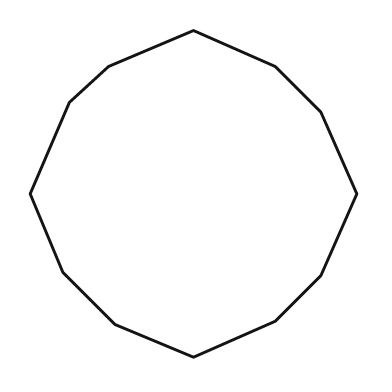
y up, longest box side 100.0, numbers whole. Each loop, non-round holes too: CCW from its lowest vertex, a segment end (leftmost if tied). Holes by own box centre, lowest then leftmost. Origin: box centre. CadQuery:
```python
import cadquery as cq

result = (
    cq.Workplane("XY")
    .moveTo(0.0, -50.0)
    .lineTo(25.0, -39.0)
    .lineTo(39.0, -25.0)
    .lineTo(50.0, 0.0)
    .lineTo(39.0, 25.0)
    .lineTo(25.0, 39.0)
    .lineTo(0.0, 50.0)
    .lineTo(-26.0, 39.0)
    .lineTo(-38.0, 28.0)
    .lineTo(-50.0, 0.0)
    .lineTo(-40.0, -24.0)
    .lineTo(-24.0, -40.0)
    .close()
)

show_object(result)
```